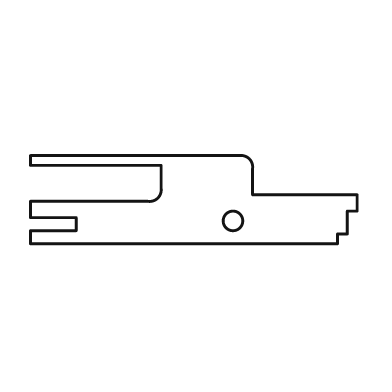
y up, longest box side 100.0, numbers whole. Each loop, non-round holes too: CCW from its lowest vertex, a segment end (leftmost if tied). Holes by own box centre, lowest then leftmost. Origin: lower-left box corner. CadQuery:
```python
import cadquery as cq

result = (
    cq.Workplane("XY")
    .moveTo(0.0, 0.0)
    .lineTo(94.0, 0.0)
    .lineTo(94.0, 3.0)
    .lineTo(97.0, 3.0)
    .lineTo(97.0, 10.0)
    .lineTo(100.0, 10.0)
    .lineTo(100.0, 15.0)
    .lineTo(68.0, 15.0)
    .lineTo(68.0, 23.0)
    .threePointArc((67.0, 26.0), (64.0, 27.0))
    .lineTo(0.0, 27.0)
    .lineTo(0.0, 24.0)
    .lineTo(40.0, 24.0)
    .lineTo(40.0, 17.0)
    .threePointArc((39.0, 14.0), (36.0, 13.0))
    .lineTo(0.0, 13.0)
    .lineTo(0.0, 8.0)
    .lineTo(14.0, 8.0)
    .lineTo(14.0, 4.0)
    .lineTo(0.0, 4.0)
    .close()
    .moveTo(62.0, 7.0)
    .circle(3.0)
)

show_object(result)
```